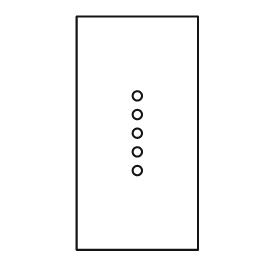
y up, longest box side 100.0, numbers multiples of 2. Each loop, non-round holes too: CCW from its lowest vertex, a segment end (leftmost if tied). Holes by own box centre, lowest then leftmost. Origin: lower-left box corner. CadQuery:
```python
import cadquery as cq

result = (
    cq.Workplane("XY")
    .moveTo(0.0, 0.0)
    .lineTo(52.0, 0.0)
    .lineTo(52.0, 100.0)
    .lineTo(0.0, 100.0)
    .close()
    .moveTo(26.0, 34.0)
    .circle(2.0)
    .moveTo(26.0, 42.0)
    .circle(2.0)
    .moveTo(26.0, 50.0)
    .circle(2.0)
    .moveTo(26.0, 58.0)
    .circle(2.0)
    .moveTo(26.0, 66.0)
    .circle(2.0)
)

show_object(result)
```